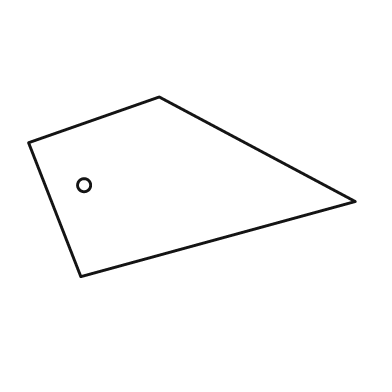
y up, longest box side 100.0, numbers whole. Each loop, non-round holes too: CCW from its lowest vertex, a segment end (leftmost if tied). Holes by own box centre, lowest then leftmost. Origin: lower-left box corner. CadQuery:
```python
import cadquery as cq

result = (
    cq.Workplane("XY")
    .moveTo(16.0, 0.0)
    .lineTo(100.0, 23.0)
    .lineTo(40.0, 55.0)
    .lineTo(0.0, 41.0)
    .close()
    .moveTo(17.0, 28.0)
    .circle(2.0)
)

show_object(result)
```